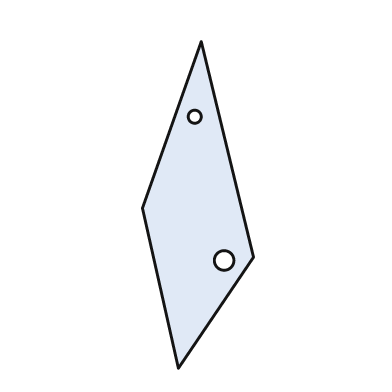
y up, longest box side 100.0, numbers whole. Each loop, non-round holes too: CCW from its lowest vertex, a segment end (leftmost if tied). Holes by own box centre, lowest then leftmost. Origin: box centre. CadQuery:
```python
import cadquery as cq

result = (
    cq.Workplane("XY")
    .moveTo(-6.0, -50.0)
    .lineTo(17.0, -16.0)
    .lineTo(1.0, 50.0)
    .lineTo(-17.0, -1.0)
    .close()
    .moveTo(8.0, -17.0)
    .circle(3.0)
    .moveTo(-1.0, 27.0)
    .circle(2.0)
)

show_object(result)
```